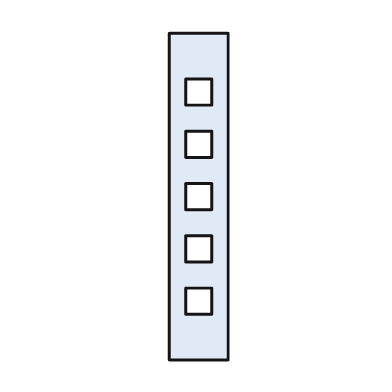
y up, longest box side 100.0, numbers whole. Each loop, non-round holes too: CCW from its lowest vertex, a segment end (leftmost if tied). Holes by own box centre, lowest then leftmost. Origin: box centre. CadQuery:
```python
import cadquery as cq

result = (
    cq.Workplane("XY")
    .moveTo(-9.0, -50.0)
    .lineTo(9.0, -50.0)
    .lineTo(9.0, 50.0)
    .lineTo(-9.0, 50.0)
    .close()
    .moveTo(-4.0, -36.0)
    .lineTo(4.0, -36.0)
    .lineTo(4.0, -28.0)
    .lineTo(-4.0, -28.0)
    .close()
    .moveTo(-4.0, -20.0)
    .lineTo(4.0, -20.0)
    .lineTo(4.0, -12.0)
    .lineTo(-4.0, -12.0)
    .close()
    .moveTo(-4.0, -4.0)
    .lineTo(4.0, -4.0)
    .lineTo(4.0, 4.0)
    .lineTo(-4.0, 4.0)
    .close()
    .moveTo(-4.0, 12.0)
    .lineTo(4.0, 12.0)
    .lineTo(4.0, 20.0)
    .lineTo(-4.0, 20.0)
    .close()
    .moveTo(-4.0, 28.0)
    .lineTo(4.0, 28.0)
    .lineTo(4.0, 36.0)
    .lineTo(-4.0, 36.0)
    .close()
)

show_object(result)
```